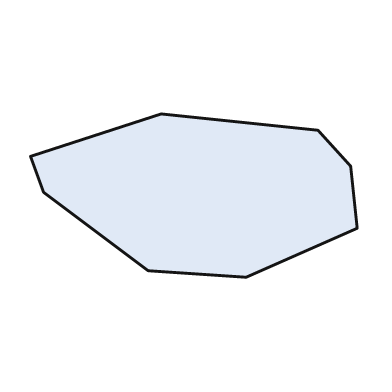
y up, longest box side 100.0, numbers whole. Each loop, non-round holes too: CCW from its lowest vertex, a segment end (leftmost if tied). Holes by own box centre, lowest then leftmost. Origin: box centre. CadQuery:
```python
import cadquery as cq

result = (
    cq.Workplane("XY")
    .moveTo(16.0, -25.0)
    .lineTo(50.0, -10.0)
    .lineTo(48.0, 9.0)
    .lineTo(38.0, 20.0)
    .lineTo(-10.0, 25.0)
    .lineTo(-50.0, 12.0)
    .lineTo(-46.0, 1.0)
    .lineTo(-14.0, -23.0)
    .close()
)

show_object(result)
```